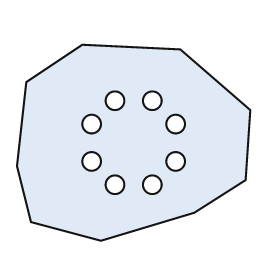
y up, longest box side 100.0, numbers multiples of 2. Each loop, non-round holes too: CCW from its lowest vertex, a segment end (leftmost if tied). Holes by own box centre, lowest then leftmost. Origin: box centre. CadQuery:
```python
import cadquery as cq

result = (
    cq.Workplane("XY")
    .moveTo(-14.0, -42.0)
    .lineTo(26.0, -30.0)
    .lineTo(48.0, -16.0)
    .lineTo(50.0, 14.0)
    .lineTo(20.0, 40.0)
    .lineTo(-22.0, 42.0)
    .lineTo(-46.0, 26.0)
    .lineTo(-50.0, -10.0)
    .lineTo(-44.0, -34.0)
    .close()
    .moveTo(-8.0, -18.0)
    .circle(4.0)
    .moveTo(8.0, -18.0)
    .circle(4.0)
    .moveTo(-18.0, -8.0)
    .circle(4.0)
    .moveTo(18.0, -8.0)
    .circle(4.0)
    .moveTo(-18.0, 8.0)
    .circle(4.0)
    .moveTo(18.0, 8.0)
    .circle(4.0)
    .moveTo(-8.0, 18.0)
    .circle(4.0)
    .moveTo(8.0, 18.0)
    .circle(4.0)
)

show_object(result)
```